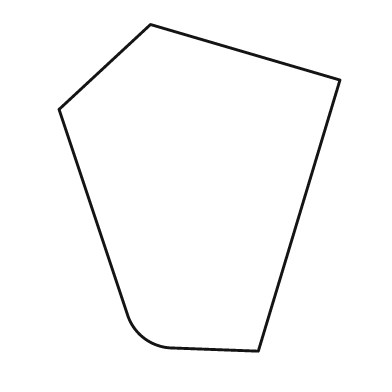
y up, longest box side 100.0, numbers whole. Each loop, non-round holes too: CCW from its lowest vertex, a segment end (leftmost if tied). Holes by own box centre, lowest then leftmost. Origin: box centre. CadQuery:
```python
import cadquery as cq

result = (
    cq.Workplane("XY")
    .moveTo(18.0, -50.0)
    .lineTo(43.0, 33.0)
    .lineTo(-15.0, 50.0)
    .lineTo(-43.0, 24.0)
    .lineTo(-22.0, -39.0)
    .threePointArc((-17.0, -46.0), (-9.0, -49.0))
    .close()
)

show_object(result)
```